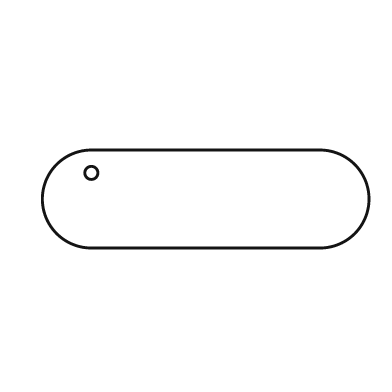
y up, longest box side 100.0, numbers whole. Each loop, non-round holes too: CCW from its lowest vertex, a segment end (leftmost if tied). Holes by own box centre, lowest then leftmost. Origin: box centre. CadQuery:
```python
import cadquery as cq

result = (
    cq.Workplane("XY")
    .moveTo(-35.0, -15.0)
    .lineTo(35.0, -15.0)
    .threePointArc((50.0, 0.0), (35.0, 15.0))
    .lineTo(-35.0, 15.0)
    .threePointArc((-50.0, 0.0), (-35.0, -15.0))
    .close()
    .moveTo(-35.0, 8.0)
    .circle(2.0)
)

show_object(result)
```